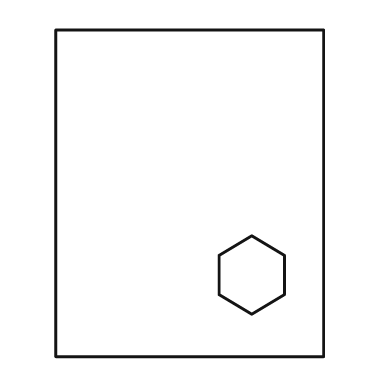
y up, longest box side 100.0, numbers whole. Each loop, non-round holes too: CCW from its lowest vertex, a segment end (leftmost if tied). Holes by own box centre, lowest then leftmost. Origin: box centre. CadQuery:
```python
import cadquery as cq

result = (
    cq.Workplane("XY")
    .moveTo(-41.0, -50.0)
    .lineTo(41.0, -50.0)
    .lineTo(41.0, 50.0)
    .lineTo(-41.0, 50.0)
    .close()
    .moveTo(19.0, -37.0)
    .lineTo(29.0, -31.0)
    .lineTo(29.0, -19.0)
    .lineTo(19.0, -13.0)
    .lineTo(9.0, -19.0)
    .lineTo(9.0, -31.0)
    .close()
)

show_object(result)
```